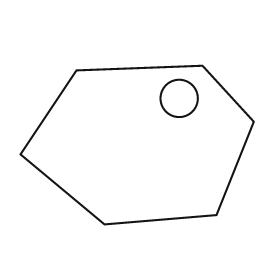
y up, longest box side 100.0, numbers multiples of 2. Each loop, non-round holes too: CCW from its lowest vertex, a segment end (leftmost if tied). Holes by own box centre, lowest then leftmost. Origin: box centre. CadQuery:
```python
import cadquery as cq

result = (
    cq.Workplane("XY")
    .moveTo(-14.0, -34.0)
    .lineTo(34.0, -30.0)
    .lineTo(50.0, 10.0)
    .lineTo(28.0, 34.0)
    .lineTo(-26.0, 32.0)
    .lineTo(-50.0, -4.0)
    .close()
    .moveTo(18.0, 20.0)
    .circle(8.0)
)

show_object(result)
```